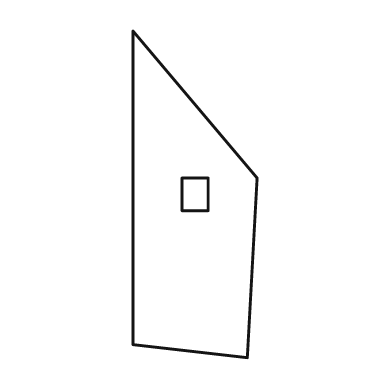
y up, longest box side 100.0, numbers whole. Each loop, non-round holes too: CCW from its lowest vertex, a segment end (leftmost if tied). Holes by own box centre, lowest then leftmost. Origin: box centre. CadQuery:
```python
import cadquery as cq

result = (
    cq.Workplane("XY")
    .moveTo(16.0, -50.0)
    .lineTo(19.0, 5.0)
    .lineTo(-19.0, 50.0)
    .lineTo(-19.0, -46.0)
    .close()
    .moveTo(-4.0, -5.0)
    .lineTo(4.0, -5.0)
    .lineTo(4.0, 5.0)
    .lineTo(-4.0, 5.0)
    .close()
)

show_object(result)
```